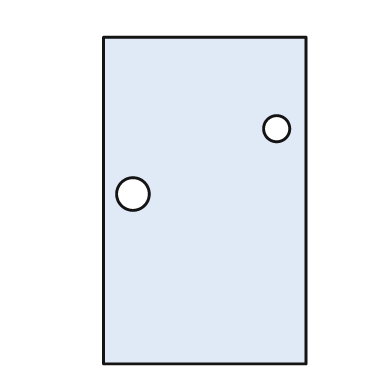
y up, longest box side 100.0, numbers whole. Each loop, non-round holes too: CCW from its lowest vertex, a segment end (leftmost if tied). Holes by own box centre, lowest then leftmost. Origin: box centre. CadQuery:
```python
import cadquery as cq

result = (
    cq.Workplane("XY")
    .moveTo(-31.0, -50.0)
    .lineTo(31.0, -50.0)
    .lineTo(31.0, 50.0)
    .lineTo(-31.0, 50.0)
    .close()
    .moveTo(-22.0, 2.0)
    .circle(5.0)
    .moveTo(22.0, 22.0)
    .circle(4.0)
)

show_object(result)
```